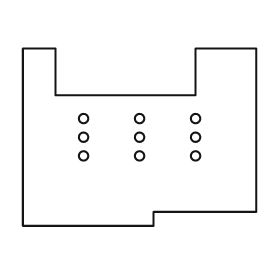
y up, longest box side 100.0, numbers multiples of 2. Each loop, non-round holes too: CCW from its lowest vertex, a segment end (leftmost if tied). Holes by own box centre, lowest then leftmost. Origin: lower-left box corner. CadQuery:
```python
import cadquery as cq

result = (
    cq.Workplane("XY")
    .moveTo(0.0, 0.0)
    .lineTo(56.0, 0.0)
    .lineTo(56.0, 6.0)
    .lineTo(100.0, 6.0)
    .lineTo(100.0, 76.0)
    .lineTo(74.0, 76.0)
    .lineTo(74.0, 56.0)
    .lineTo(14.0, 56.0)
    .lineTo(14.0, 76.0)
    .lineTo(0.0, 76.0)
    .close()
    .moveTo(26.0, 30.0)
    .circle(2.0)
    .moveTo(50.0, 30.0)
    .circle(2.0)
    .moveTo(74.0, 30.0)
    .circle(2.0)
    .moveTo(26.0, 38.0)
    .circle(2.0)
    .moveTo(50.0, 38.0)
    .circle(2.0)
    .moveTo(74.0, 38.0)
    .circle(2.0)
    .moveTo(26.0, 46.0)
    .circle(2.0)
    .moveTo(50.0, 46.0)
    .circle(2.0)
    .moveTo(74.0, 46.0)
    .circle(2.0)
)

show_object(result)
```